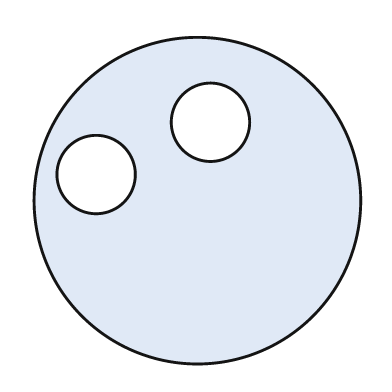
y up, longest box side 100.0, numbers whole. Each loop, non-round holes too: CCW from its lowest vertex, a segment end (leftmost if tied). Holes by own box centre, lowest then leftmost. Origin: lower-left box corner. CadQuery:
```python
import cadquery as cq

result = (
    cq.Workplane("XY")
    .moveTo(50.0, 50.0)
    .circle(50.0)
    .moveTo(19.0, 58.0)
    .circle(12.0)
    .moveTo(54.0, 74.0)
    .circle(12.0)
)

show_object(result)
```